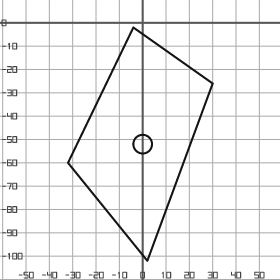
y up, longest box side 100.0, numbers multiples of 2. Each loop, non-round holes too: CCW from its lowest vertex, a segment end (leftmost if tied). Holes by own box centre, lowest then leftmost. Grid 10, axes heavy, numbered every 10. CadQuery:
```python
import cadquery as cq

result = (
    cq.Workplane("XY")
    .moveTo(2.0, -102.0)
    .lineTo(30.0, -26.0)
    .lineTo(-4.0, -2.0)
    .lineTo(-32.0, -60.0)
    .close()
    .moveTo(0.0, -52.0)
    .circle(4.0)
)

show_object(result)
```